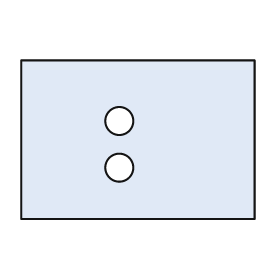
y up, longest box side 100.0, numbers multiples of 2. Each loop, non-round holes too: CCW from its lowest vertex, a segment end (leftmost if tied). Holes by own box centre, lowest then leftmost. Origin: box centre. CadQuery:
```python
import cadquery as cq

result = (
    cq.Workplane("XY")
    .moveTo(-50.0, -34.0)
    .lineTo(50.0, -34.0)
    .lineTo(50.0, 34.0)
    .lineTo(-50.0, 34.0)
    .close()
    .moveTo(-8.0, -12.0)
    .circle(6.0)
    .moveTo(-8.0, 8.0)
    .circle(6.0)
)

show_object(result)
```